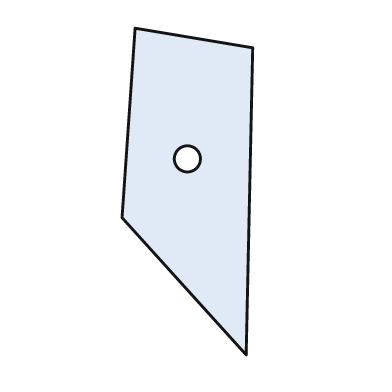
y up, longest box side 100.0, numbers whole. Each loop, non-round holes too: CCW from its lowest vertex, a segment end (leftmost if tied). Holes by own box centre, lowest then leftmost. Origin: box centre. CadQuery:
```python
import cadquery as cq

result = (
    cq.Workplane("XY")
    .moveTo(18.0, -50.0)
    .lineTo(20.0, 44.0)
    .lineTo(-16.0, 50.0)
    .lineTo(-20.0, -8.0)
    .close()
    .moveTo(0.0, 10.0)
    .circle(4.0)
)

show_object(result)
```